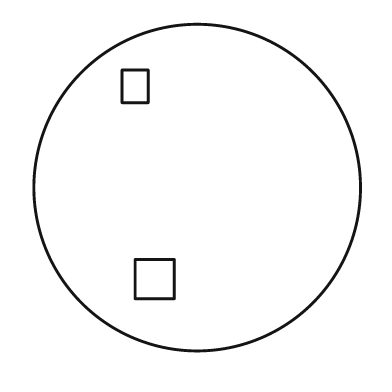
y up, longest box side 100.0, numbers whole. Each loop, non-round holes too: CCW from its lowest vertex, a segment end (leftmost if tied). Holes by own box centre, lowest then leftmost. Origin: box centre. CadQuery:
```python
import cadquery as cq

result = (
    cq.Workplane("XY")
    .moveTo(0.0, 0.0)
    .circle(50.0)
    .moveTo(-19.0, -34.0)
    .lineTo(-7.0, -34.0)
    .lineTo(-7.0, -22.0)
    .lineTo(-19.0, -22.0)
    .close()
    .moveTo(-23.0, 26.0)
    .lineTo(-15.0, 26.0)
    .lineTo(-15.0, 36.0)
    .lineTo(-23.0, 36.0)
    .close()
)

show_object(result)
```